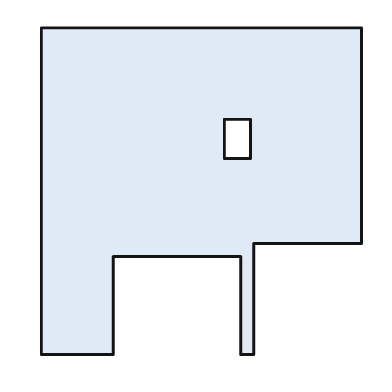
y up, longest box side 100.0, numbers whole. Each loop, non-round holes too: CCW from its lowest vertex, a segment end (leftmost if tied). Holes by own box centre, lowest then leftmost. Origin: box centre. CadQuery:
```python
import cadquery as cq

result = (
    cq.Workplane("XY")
    .moveTo(-49.0, -50.0)
    .lineTo(-27.0, -50.0)
    .lineTo(-27.0, -20.0)
    .lineTo(12.0, -20.0)
    .lineTo(12.0, -50.0)
    .lineTo(16.0, -50.0)
    .lineTo(16.0, -16.0)
    .lineTo(49.0, -16.0)
    .lineTo(49.0, 50.0)
    .lineTo(-49.0, 50.0)
    .close()
    .moveTo(7.0, 10.0)
    .lineTo(15.0, 10.0)
    .lineTo(15.0, 22.0)
    .lineTo(7.0, 22.0)
    .close()
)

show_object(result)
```